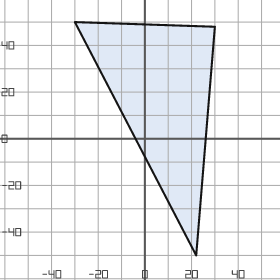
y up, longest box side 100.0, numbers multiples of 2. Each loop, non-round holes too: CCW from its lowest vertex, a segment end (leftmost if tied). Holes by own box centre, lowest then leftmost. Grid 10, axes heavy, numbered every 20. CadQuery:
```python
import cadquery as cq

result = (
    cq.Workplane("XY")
    .moveTo(22.0, -50.0)
    .lineTo(30.0, 48.0)
    .lineTo(-30.0, 50.0)
    .close()
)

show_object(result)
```